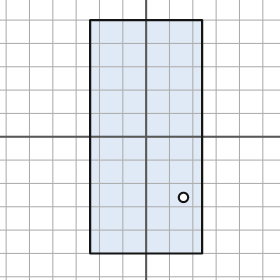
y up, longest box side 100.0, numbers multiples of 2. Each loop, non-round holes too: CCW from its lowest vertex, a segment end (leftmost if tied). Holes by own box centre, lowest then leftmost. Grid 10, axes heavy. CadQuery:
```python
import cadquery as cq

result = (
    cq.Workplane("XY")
    .moveTo(-24.0, -50.0)
    .lineTo(24.0, -50.0)
    .lineTo(24.0, 50.0)
    .lineTo(-24.0, 50.0)
    .close()
    .moveTo(16.0, -26.0)
    .circle(2.0)
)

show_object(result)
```